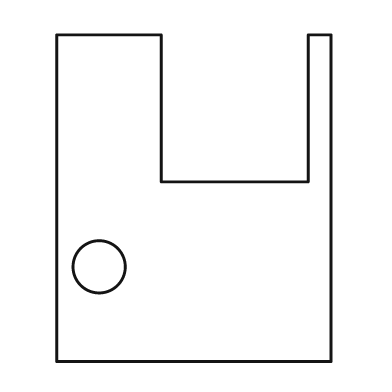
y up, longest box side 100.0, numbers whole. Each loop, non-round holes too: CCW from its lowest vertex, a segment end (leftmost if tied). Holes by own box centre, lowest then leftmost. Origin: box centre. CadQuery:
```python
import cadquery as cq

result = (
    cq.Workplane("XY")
    .moveTo(-42.0, -50.0)
    .lineTo(42.0, -50.0)
    .lineTo(42.0, 50.0)
    .lineTo(35.0, 50.0)
    .lineTo(35.0, 5.0)
    .lineTo(-10.0, 5.0)
    .lineTo(-10.0, 50.0)
    .lineTo(-42.0, 50.0)
    .close()
    .moveTo(-29.0, -21.0)
    .circle(8.0)
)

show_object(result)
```